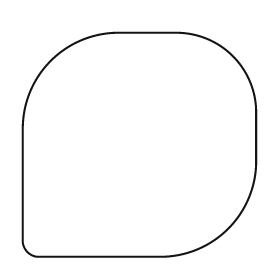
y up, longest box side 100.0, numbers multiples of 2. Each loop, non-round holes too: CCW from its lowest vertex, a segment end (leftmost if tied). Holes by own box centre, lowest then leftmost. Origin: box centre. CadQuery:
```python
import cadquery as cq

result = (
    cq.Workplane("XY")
    .moveTo(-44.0, -48.0)
    .lineTo(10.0, -48.0)
    .threePointArc((38.0, -36.0), (50.0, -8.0))
    .lineTo(50.0, 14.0)
    .threePointArc((40.0, 38.0), (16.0, 48.0))
    .lineTo(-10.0, 48.0)
    .threePointArc((-38.0, 36.0), (-50.0, 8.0))
    .lineTo(-50.0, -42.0)
    .threePointArc((-48.0, -46.0), (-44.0, -48.0))
    .close()
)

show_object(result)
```